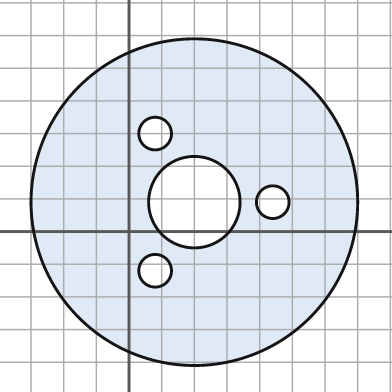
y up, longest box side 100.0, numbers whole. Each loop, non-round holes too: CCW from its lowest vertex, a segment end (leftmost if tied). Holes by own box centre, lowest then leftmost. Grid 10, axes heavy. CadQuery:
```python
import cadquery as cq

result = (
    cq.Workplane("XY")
    .moveTo(20.0, 9.0)
    .circle(50.0)
    .moveTo(8.0, -12.0)
    .circle(5.0)
    .moveTo(20.0, 9.0)
    .circle(14.0)
    .moveTo(44.0, 9.0)
    .circle(5.0)
    .moveTo(8.0, 30.0)
    .circle(5.0)
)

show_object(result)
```